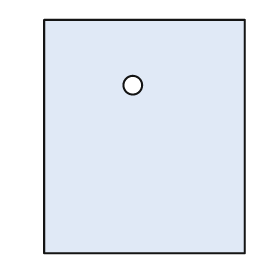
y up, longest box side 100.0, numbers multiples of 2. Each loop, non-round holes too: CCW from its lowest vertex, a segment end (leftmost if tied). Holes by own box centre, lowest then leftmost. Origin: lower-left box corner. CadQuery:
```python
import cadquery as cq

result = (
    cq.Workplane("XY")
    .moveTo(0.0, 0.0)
    .lineTo(86.0, 0.0)
    .lineTo(86.0, 100.0)
    .lineTo(0.0, 100.0)
    .close()
    .moveTo(38.0, 72.0)
    .circle(4.0)
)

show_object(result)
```